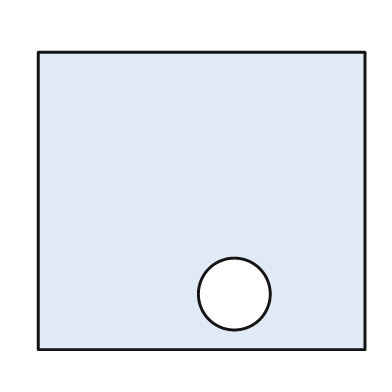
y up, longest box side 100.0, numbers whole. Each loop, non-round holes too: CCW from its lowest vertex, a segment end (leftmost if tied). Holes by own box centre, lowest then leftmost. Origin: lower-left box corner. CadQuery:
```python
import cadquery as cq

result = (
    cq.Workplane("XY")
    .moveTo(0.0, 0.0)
    .lineTo(100.0, 0.0)
    .lineTo(100.0, 91.0)
    .lineTo(0.0, 91.0)
    .close()
    .moveTo(60.0, 17.0)
    .circle(11.0)
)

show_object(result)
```